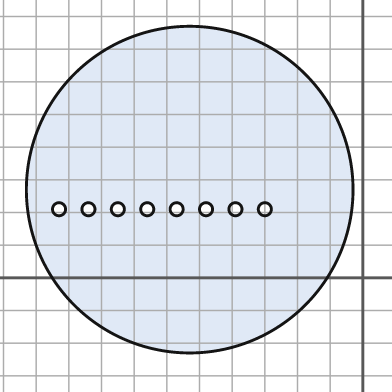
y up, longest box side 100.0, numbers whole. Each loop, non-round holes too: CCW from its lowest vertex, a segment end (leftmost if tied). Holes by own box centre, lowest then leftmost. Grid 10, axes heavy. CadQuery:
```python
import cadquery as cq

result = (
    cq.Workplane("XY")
    .moveTo(-53.0, 27.0)
    .circle(50.0)
    .moveTo(-93.0, 21.0)
    .circle(2.0)
    .moveTo(-84.0, 21.0)
    .circle(2.0)
    .moveTo(-75.0, 21.0)
    .circle(2.0)
    .moveTo(-66.0, 21.0)
    .circle(2.0)
    .moveTo(-57.0, 21.0)
    .circle(2.0)
    .moveTo(-48.0, 21.0)
    .circle(2.0)
    .moveTo(-39.0, 21.0)
    .circle(2.0)
    .moveTo(-30.0, 21.0)
    .circle(2.0)
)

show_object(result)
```